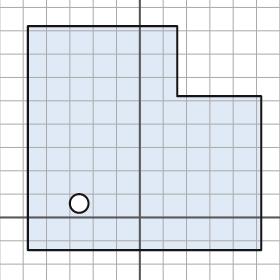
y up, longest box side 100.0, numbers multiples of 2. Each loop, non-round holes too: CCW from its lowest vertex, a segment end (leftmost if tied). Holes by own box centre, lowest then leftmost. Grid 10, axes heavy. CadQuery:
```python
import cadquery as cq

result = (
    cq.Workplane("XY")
    .moveTo(-48.0, -14.0)
    .lineTo(52.0, -14.0)
    .lineTo(52.0, 52.0)
    .lineTo(16.0, 52.0)
    .lineTo(16.0, 82.0)
    .lineTo(-48.0, 82.0)
    .close()
    .moveTo(-26.0, 6.0)
    .circle(4.0)
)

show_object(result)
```